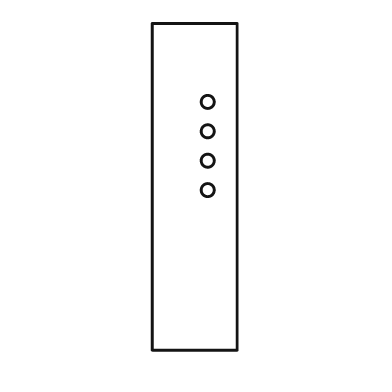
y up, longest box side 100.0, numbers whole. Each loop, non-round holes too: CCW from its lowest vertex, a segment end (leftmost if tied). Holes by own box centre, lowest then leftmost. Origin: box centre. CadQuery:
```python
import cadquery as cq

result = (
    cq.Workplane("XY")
    .moveTo(-13.0, -50.0)
    .lineTo(13.0, -50.0)
    .lineTo(13.0, 50.0)
    .lineTo(-13.0, 50.0)
    .close()
    .moveTo(4.0, -1.0)
    .circle(2.0)
    .moveTo(4.0, 8.0)
    .circle(2.0)
    .moveTo(4.0, 17.0)
    .circle(2.0)
    .moveTo(4.0, 26.0)
    .circle(2.0)
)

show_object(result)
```